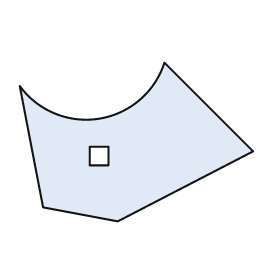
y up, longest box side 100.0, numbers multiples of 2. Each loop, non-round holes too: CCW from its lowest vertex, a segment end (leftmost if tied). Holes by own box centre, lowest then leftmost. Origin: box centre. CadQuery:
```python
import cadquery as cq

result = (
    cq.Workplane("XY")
    .moveTo(-8.0, -34.0)
    .lineTo(50.0, -4.0)
    .lineTo(12.0, 34.0)
    .threePointArc((-16.0, 10.0), (-50.0, 24.0))
    .lineTo(-40.0, -28.0)
    .close()
    .moveTo(-20.0, -10.0)
    .lineTo(-12.0, -10.0)
    .lineTo(-12.0, -2.0)
    .lineTo(-20.0, -2.0)
    .close()
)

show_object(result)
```